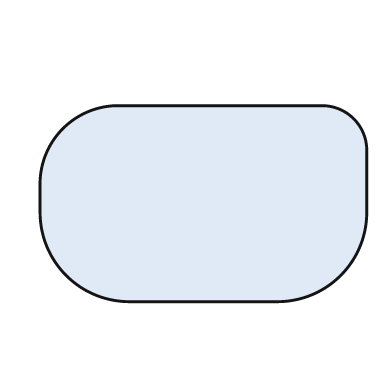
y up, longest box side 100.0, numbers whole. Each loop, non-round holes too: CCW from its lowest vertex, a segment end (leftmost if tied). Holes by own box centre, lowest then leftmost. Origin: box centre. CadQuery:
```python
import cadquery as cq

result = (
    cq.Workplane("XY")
    .moveTo(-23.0, -30.0)
    .lineTo(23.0, -30.0)
    .threePointArc((42.0, -22.0), (50.0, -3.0))
    .lineTo(50.0, 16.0)
    .threePointArc((46.0, 26.0), (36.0, 30.0))
    .lineTo(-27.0, 30.0)
    .threePointArc((-43.0, 23.0), (-50.0, 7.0))
    .lineTo(-50.0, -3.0)
    .threePointArc((-42.0, -22.0), (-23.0, -30.0))
    .close()
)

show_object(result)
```